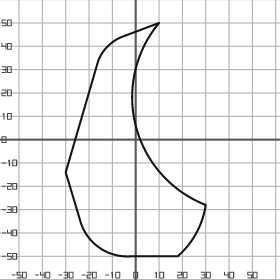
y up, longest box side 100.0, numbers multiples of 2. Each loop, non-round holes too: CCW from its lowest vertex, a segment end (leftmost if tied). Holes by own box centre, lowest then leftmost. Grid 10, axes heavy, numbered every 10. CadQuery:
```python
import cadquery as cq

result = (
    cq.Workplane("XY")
    .moveTo(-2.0, -50.0)
    .lineTo(18.0, -50.0)
    .threePointArc((26.0, -40.0), (30.0, -28.0))
    .threePointArc((0.0, 6.0), (10.0, 50.0))
    .lineTo(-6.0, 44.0)
    .threePointArc((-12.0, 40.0), (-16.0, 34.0))
    .lineTo(-30.0, -14.0)
    .lineTo(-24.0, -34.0)
    .threePointArc((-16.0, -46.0), (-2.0, -50.0))
    .close()
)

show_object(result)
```